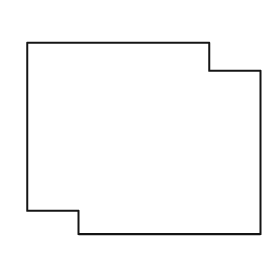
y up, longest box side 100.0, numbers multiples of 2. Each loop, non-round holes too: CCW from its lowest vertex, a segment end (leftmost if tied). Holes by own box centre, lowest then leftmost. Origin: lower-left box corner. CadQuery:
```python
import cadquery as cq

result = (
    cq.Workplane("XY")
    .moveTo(22.0, 0.0)
    .lineTo(100.0, 0.0)
    .lineTo(100.0, 70.0)
    .lineTo(78.0, 70.0)
    .lineTo(78.0, 82.0)
    .lineTo(0.0, 82.0)
    .lineTo(0.0, 10.0)
    .lineTo(22.0, 10.0)
    .close()
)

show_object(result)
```